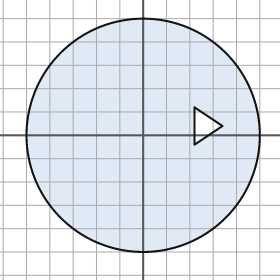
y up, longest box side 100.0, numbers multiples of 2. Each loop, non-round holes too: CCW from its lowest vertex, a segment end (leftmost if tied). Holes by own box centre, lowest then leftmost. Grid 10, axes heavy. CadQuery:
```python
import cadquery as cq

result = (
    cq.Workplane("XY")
    .moveTo(0.0, 0.0)
    .circle(50.0)
    .moveTo(22.0, -4.0)
    .lineTo(34.0, 4.0)
    .lineTo(22.0, 12.0)
    .close()
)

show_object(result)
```